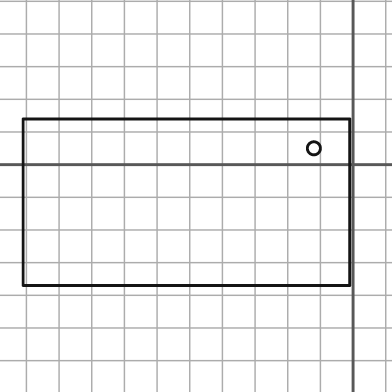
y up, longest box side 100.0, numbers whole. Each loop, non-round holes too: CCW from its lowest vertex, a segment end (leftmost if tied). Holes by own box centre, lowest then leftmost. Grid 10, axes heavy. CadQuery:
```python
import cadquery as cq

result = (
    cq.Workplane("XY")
    .moveTo(-101.0, -37.0)
    .lineTo(-1.0, -37.0)
    .lineTo(-1.0, 14.0)
    .lineTo(-101.0, 14.0)
    .close()
    .moveTo(-12.0, 5.0)
    .circle(2.0)
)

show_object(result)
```